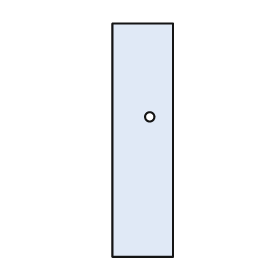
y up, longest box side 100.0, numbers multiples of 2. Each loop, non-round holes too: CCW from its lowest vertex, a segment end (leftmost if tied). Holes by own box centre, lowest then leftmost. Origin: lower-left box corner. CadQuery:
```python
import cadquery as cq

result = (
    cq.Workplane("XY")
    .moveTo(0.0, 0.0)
    .lineTo(26.0, 0.0)
    .lineTo(26.0, 100.0)
    .lineTo(0.0, 100.0)
    .close()
    .moveTo(16.0, 60.0)
    .circle(2.0)
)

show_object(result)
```